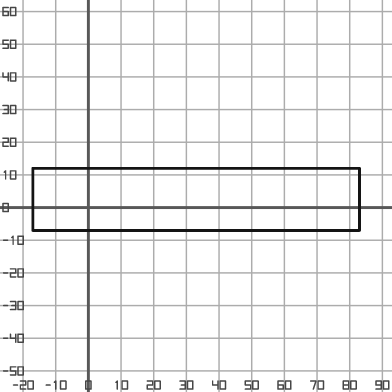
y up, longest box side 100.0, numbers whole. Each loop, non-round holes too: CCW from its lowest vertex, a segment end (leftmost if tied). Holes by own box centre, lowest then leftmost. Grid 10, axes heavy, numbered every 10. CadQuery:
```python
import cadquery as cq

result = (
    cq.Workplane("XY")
    .moveTo(-17.0, -7.0)
    .lineTo(83.0, -7.0)
    .lineTo(83.0, 12.0)
    .lineTo(-17.0, 12.0)
    .close()
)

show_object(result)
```